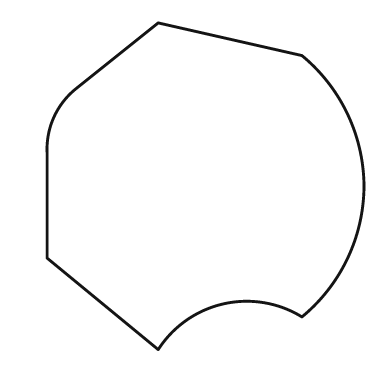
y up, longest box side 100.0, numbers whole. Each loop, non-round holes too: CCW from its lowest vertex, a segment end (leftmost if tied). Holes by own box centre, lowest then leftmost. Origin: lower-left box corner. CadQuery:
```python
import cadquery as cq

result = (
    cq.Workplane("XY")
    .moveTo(34.0, 0.0)
    .threePointArc((54.0, 14.0), (78.0, 10.0))
    .threePointArc((92.0, 28.0), (97.0, 50.0))
    .threePointArc((92.0, 72.0), (78.0, 90.0))
    .lineTo(34.0, 100.0)
    .lineTo(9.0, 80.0)
    .threePointArc((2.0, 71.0), (0.0, 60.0))
    .lineTo(0.0, 28.0)
    .close()
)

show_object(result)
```